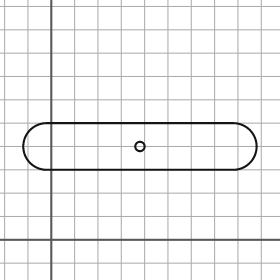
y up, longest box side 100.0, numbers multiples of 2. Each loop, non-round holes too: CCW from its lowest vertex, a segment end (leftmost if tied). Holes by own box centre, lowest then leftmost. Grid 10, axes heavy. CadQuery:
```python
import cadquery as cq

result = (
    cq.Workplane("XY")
    .moveTo(-2.0, 30.0)
    .lineTo(78.0, 30.0)
    .threePointArc((88.0, 40.0), (78.0, 50.0))
    .lineTo(-2.0, 50.0)
    .threePointArc((-12.0, 40.0), (-2.0, 30.0))
    .close()
    .moveTo(38.0, 40.0)
    .circle(2.0)
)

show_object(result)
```